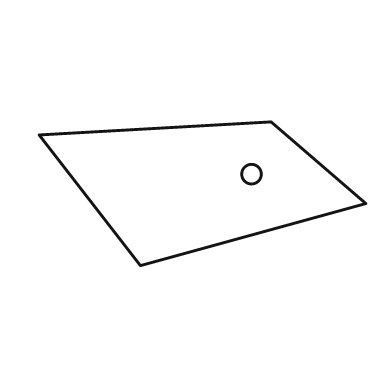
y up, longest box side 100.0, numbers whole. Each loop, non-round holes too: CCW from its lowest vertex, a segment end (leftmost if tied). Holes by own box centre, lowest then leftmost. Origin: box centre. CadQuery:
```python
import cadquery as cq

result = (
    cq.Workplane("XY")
    .moveTo(-19.0, -22.0)
    .lineTo(50.0, -3.0)
    .lineTo(21.0, 22.0)
    .lineTo(-50.0, 18.0)
    .close()
    .moveTo(15.0, 6.0)
    .circle(3.0)
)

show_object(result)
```